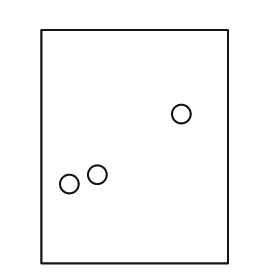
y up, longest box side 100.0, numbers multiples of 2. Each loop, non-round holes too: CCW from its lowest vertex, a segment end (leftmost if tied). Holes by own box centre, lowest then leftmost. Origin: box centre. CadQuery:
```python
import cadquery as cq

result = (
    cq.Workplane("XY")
    .moveTo(-40.0, -50.0)
    .lineTo(40.0, -50.0)
    .lineTo(40.0, 50.0)
    .lineTo(-40.0, 50.0)
    .close()
    .moveTo(-28.0, -16.0)
    .circle(4.0)
    .moveTo(-16.0, -12.0)
    .circle(4.0)
    .moveTo(20.0, 14.0)
    .circle(4.0)
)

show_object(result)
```